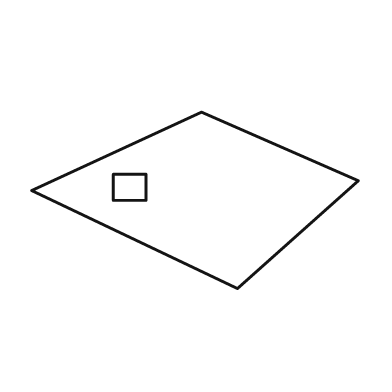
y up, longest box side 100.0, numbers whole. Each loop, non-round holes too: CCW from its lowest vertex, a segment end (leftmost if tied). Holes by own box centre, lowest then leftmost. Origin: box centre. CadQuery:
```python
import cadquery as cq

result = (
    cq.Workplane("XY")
    .moveTo(13.0, -27.0)
    .lineTo(50.0, 6.0)
    .lineTo(2.0, 27.0)
    .lineTo(-50.0, 3.0)
    .close()
    .moveTo(-25.0, 0.0)
    .lineTo(-15.0, 0.0)
    .lineTo(-15.0, 8.0)
    .lineTo(-25.0, 8.0)
    .close()
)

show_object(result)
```